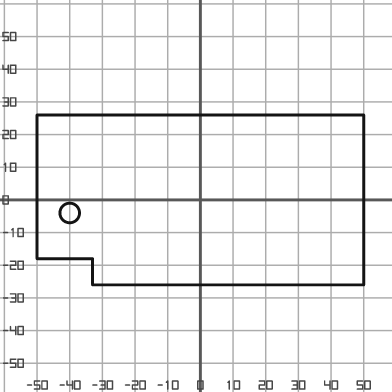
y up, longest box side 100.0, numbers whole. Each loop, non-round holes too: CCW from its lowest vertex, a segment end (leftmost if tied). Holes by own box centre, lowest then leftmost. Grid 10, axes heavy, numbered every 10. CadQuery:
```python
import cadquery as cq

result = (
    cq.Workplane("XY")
    .moveTo(-33.0, -26.0)
    .lineTo(50.0, -26.0)
    .lineTo(50.0, 26.0)
    .lineTo(-50.0, 26.0)
    .lineTo(-50.0, -18.0)
    .lineTo(-33.0, -18.0)
    .close()
    .moveTo(-40.0, -4.0)
    .circle(3.0)
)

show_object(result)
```